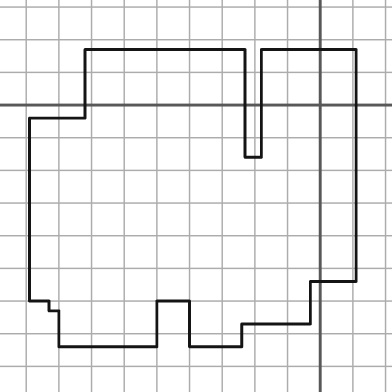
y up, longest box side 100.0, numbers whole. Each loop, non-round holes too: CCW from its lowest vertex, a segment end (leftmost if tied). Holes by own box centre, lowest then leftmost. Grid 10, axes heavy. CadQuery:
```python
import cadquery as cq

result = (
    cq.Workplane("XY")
    .moveTo(-80.0, -74.0)
    .lineTo(-50.0, -74.0)
    .lineTo(-50.0, -60.0)
    .lineTo(-40.0, -60.0)
    .lineTo(-40.0, -74.0)
    .lineTo(-24.0, -74.0)
    .lineTo(-24.0, -67.0)
    .lineTo(-3.0, -67.0)
    .lineTo(-3.0, -54.0)
    .lineTo(11.0, -54.0)
    .lineTo(11.0, 17.0)
    .lineTo(-18.0, 17.0)
    .lineTo(-18.0, -16.0)
    .lineTo(-23.0, -16.0)
    .lineTo(-23.0, 17.0)
    .lineTo(-72.0, 17.0)
    .lineTo(-72.0, -4.0)
    .lineTo(-89.0, -4.0)
    .lineTo(-89.0, -60.0)
    .lineTo(-83.0, -60.0)
    .lineTo(-83.0, -63.0)
    .lineTo(-80.0, -63.0)
    .close()
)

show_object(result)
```